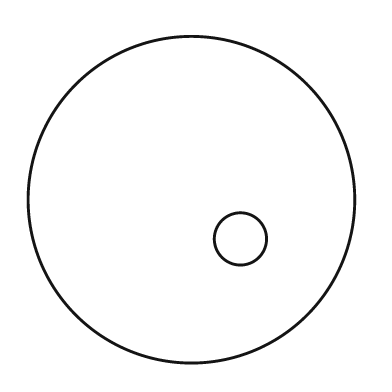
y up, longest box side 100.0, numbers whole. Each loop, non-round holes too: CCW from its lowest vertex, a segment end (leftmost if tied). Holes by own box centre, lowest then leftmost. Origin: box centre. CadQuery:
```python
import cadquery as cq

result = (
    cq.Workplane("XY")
    .moveTo(0.0, 0.0)
    .circle(50.0)
    .moveTo(15.0, -12.0)
    .circle(8.0)
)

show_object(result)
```